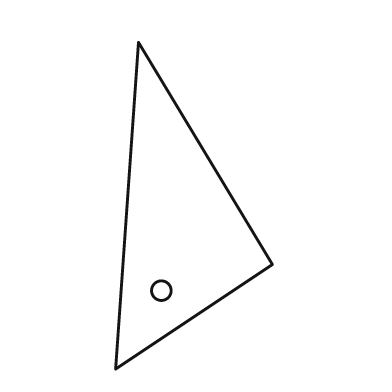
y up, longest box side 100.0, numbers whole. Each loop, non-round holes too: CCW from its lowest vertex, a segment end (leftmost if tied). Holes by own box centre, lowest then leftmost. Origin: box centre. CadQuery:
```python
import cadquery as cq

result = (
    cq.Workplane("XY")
    .moveTo(-24.0, -50.0)
    .lineTo(24.0, -18.0)
    .lineTo(-17.0, 50.0)
    .close()
    .moveTo(-10.0, -26.0)
    .circle(3.0)
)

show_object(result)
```